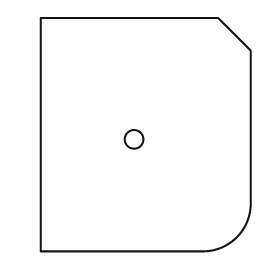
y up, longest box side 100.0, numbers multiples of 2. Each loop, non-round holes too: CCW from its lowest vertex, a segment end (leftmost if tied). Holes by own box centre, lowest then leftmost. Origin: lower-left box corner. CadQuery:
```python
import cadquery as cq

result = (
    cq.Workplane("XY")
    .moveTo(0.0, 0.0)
    .lineTo(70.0, 0.0)
    .threePointArc((84.0, 6.0), (90.0, 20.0))
    .lineTo(90.0, 86.0)
    .lineTo(76.0, 100.0)
    .lineTo(0.0, 100.0)
    .close()
    .moveTo(40.0, 48.0)
    .circle(4.0)
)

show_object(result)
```